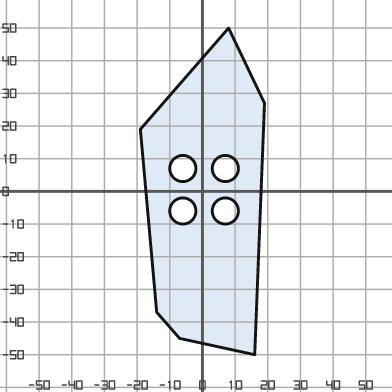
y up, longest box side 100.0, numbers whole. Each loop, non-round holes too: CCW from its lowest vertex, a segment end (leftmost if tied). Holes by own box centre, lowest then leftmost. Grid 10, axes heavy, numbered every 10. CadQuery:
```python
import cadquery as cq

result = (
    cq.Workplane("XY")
    .moveTo(16.0, -50.0)
    .lineTo(19.0, 27.0)
    .lineTo(8.0, 50.0)
    .lineTo(-19.0, 19.0)
    .lineTo(-14.0, -37.0)
    .lineTo(-7.0, -45.0)
    .close()
    .moveTo(-6.0, -6.0)
    .circle(4.0)
    .moveTo(7.0, -6.0)
    .circle(4.0)
    .moveTo(-6.0, 7.0)
    .circle(4.0)
    .moveTo(7.0, 7.0)
    .circle(4.0)
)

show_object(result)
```